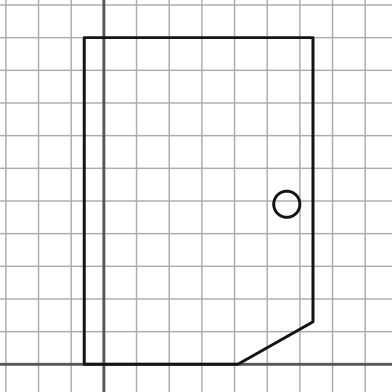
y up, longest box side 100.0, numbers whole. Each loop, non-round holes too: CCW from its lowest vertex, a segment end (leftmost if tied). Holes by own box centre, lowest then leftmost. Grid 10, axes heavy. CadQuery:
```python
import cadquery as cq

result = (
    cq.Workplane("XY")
    .moveTo(-6.0, 0.0)
    .lineTo(41.0, 0.0)
    .lineTo(64.0, 13.0)
    .lineTo(64.0, 100.0)
    .lineTo(-6.0, 100.0)
    .close()
    .moveTo(56.0, 49.0)
    .circle(4.0)
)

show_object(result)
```